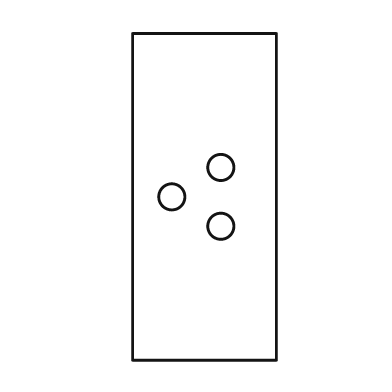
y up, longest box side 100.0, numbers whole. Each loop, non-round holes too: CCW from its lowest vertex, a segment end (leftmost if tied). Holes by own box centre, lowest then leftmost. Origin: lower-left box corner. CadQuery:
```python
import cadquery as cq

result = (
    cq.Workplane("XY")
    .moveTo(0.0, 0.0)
    .lineTo(44.0, 0.0)
    .lineTo(44.0, 100.0)
    .lineTo(0.0, 100.0)
    .close()
    .moveTo(27.0, 41.0)
    .circle(4.0)
    .moveTo(12.0, 50.0)
    .circle(4.0)
    .moveTo(27.0, 59.0)
    .circle(4.0)
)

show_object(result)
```